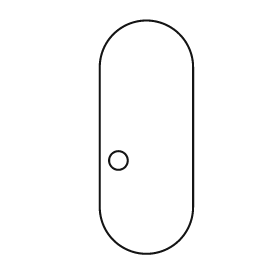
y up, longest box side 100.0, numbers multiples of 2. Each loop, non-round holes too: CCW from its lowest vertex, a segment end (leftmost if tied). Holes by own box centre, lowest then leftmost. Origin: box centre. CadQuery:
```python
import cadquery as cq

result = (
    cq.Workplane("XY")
    .moveTo(-20.0, -30.0)
    .threePointArc((0.0, -50.0), (20.0, -30.0))
    .lineTo(20.0, 30.0)
    .threePointArc((0.0, 50.0), (-20.0, 30.0))
    .close()
    .moveTo(-12.0, -10.0)
    .circle(4.0)
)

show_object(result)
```